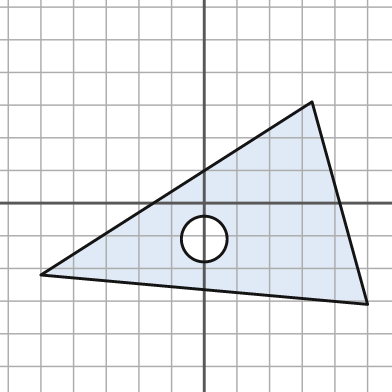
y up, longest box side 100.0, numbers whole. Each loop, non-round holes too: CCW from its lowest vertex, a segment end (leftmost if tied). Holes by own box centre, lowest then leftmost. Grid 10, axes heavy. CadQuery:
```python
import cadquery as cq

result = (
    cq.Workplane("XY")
    .moveTo(50.0, -31.0)
    .lineTo(33.0, 31.0)
    .lineTo(-50.0, -22.0)
    .close()
    .moveTo(0.0, -11.0)
    .circle(7.0)
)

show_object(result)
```